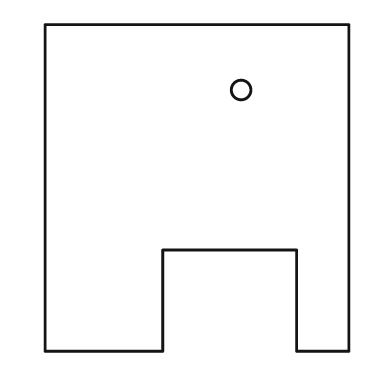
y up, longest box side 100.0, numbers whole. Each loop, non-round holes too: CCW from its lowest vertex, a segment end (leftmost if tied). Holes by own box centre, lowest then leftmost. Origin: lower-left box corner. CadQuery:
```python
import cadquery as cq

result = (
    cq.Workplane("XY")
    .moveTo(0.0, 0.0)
    .lineTo(36.0, 0.0)
    .lineTo(36.0, 31.0)
    .lineTo(77.0, 31.0)
    .lineTo(77.0, 0.0)
    .lineTo(93.0, 0.0)
    .lineTo(93.0, 100.0)
    .lineTo(0.0, 100.0)
    .close()
    .moveTo(60.0, 80.0)
    .circle(3.0)
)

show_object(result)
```